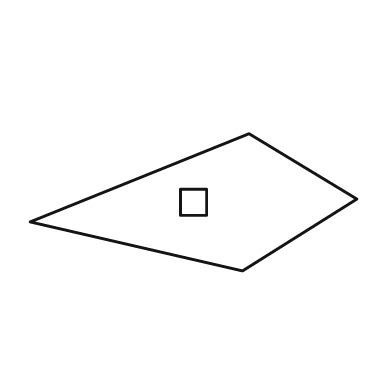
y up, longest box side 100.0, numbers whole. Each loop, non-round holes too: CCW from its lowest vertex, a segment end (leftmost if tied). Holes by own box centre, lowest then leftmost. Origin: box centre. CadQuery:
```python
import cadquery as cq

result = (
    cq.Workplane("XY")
    .moveTo(15.0, -21.0)
    .lineTo(50.0, 1.0)
    .lineTo(17.0, 21.0)
    .lineTo(-50.0, -6.0)
    .close()
    .moveTo(-4.0, -4.0)
    .lineTo(4.0, -4.0)
    .lineTo(4.0, 4.0)
    .lineTo(-4.0, 4.0)
    .close()
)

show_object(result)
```